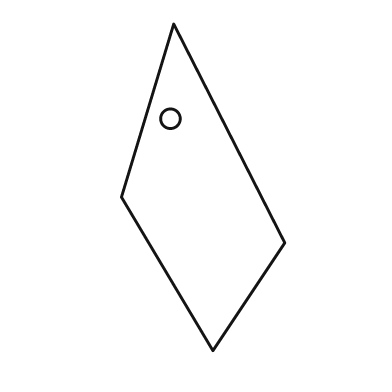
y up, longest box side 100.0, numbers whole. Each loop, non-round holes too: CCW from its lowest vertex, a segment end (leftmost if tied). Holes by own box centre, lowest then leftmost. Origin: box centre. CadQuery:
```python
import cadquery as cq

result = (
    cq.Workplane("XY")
    .moveTo(3.0, -50.0)
    .lineTo(25.0, -17.0)
    .lineTo(-9.0, 50.0)
    .lineTo(-25.0, -3.0)
    .close()
    .moveTo(-10.0, 21.0)
    .circle(3.0)
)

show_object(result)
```